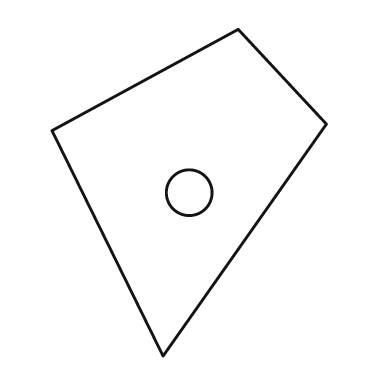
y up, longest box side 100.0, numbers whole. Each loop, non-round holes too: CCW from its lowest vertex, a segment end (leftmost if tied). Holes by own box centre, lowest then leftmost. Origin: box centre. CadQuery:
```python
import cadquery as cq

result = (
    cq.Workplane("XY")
    .moveTo(-8.0, -50.0)
    .lineTo(42.0, 21.0)
    .lineTo(15.0, 50.0)
    .lineTo(-42.0, 19.0)
    .close()
    .moveTo(0.0, 0.0)
    .circle(7.0)
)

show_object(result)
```